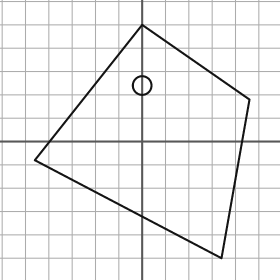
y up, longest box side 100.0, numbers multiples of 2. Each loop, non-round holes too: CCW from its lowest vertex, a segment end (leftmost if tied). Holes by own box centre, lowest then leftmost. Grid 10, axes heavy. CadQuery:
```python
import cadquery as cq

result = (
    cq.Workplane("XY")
    .moveTo(34.0, -50.0)
    .lineTo(46.0, 18.0)
    .lineTo(0.0, 50.0)
    .lineTo(-46.0, -8.0)
    .close()
    .moveTo(0.0, 24.0)
    .circle(4.0)
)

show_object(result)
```